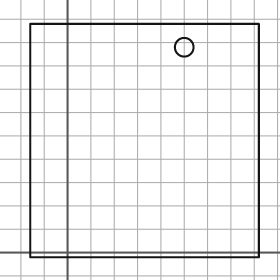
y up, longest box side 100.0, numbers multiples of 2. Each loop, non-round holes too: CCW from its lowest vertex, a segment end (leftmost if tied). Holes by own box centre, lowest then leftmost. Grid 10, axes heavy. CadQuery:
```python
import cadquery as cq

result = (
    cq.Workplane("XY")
    .moveTo(-16.0, -2.0)
    .lineTo(82.0, -2.0)
    .lineTo(82.0, 98.0)
    .lineTo(-16.0, 98.0)
    .close()
    .moveTo(50.0, 88.0)
    .circle(4.0)
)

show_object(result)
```